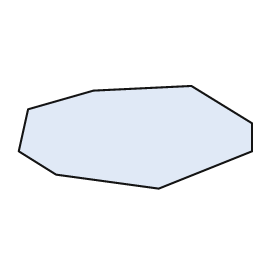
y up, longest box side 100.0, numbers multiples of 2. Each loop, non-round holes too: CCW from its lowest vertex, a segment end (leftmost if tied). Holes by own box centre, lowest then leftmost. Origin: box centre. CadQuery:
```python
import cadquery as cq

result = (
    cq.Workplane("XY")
    .moveTo(10.0, -22.0)
    .lineTo(50.0, -6.0)
    .lineTo(50.0, 6.0)
    .lineTo(24.0, 22.0)
    .lineTo(-18.0, 20.0)
    .lineTo(-46.0, 12.0)
    .lineTo(-50.0, -6.0)
    .lineTo(-34.0, -16.0)
    .close()
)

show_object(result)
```